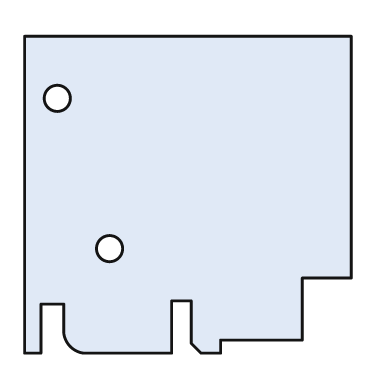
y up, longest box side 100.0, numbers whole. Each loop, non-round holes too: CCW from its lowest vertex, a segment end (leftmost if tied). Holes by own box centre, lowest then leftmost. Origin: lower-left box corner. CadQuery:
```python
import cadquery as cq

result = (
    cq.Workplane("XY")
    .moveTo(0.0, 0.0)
    .lineTo(5.0, 0.0)
    .lineTo(5.0, 15.0)
    .lineTo(12.0, 15.0)
    .lineTo(12.0, 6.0)
    .threePointArc((14.0, 2.0), (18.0, 0.0))
    .lineTo(45.0, 0.0)
    .lineTo(45.0, 16.0)
    .lineTo(51.0, 16.0)
    .lineTo(51.0, 3.0)
    .lineTo(54.0, 0.0)
    .lineTo(60.0, 0.0)
    .lineTo(60.0, 4.0)
    .lineTo(85.0, 4.0)
    .lineTo(85.0, 23.0)
    .lineTo(100.0, 23.0)
    .lineTo(100.0, 97.0)
    .lineTo(0.0, 97.0)
    .close()
    .moveTo(26.0, 32.0)
    .circle(4.0)
    .moveTo(10.0, 78.0)
    .circle(4.0)
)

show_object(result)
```